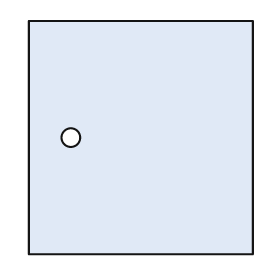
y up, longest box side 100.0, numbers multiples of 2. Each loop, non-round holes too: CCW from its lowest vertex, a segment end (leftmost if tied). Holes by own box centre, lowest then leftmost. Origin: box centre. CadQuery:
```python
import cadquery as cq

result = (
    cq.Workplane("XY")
    .moveTo(-48.0, -50.0)
    .lineTo(48.0, -50.0)
    .lineTo(48.0, 50.0)
    .lineTo(-48.0, 50.0)
    .close()
    .moveTo(-30.0, 0.0)
    .circle(4.0)
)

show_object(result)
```